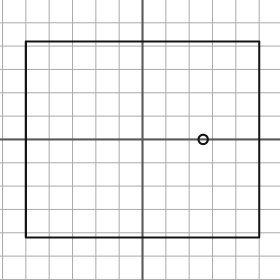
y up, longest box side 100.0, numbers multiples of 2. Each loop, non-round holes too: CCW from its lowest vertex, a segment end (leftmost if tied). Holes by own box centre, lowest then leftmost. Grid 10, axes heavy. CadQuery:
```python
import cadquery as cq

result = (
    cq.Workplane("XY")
    .moveTo(-50.0, -42.0)
    .lineTo(50.0, -42.0)
    .lineTo(50.0, 42.0)
    .lineTo(-50.0, 42.0)
    .close()
    .moveTo(26.0, 0.0)
    .circle(2.0)
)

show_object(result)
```